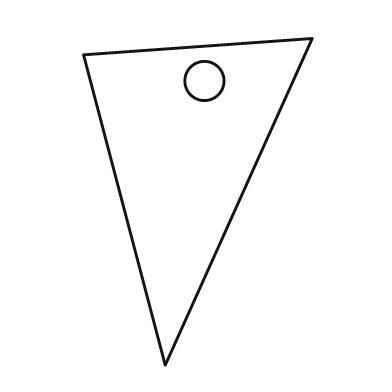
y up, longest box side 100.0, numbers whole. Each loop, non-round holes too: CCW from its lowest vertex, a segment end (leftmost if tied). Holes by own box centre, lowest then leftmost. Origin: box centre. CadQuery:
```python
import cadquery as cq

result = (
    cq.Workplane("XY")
    .moveTo(-10.0, -50.0)
    .lineTo(35.0, 50.0)
    .lineTo(-35.0, 45.0)
    .close()
    .moveTo(2.0, 37.0)
    .circle(6.0)
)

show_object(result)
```